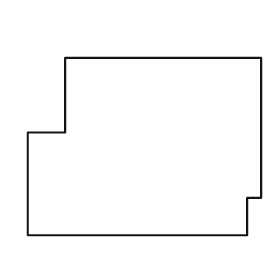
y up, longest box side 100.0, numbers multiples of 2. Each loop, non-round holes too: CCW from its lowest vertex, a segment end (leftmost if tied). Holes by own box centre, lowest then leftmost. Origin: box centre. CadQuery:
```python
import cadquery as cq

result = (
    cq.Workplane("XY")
    .moveTo(-50.0, -38.0)
    .lineTo(44.0, -38.0)
    .lineTo(44.0, -22.0)
    .lineTo(50.0, -22.0)
    .lineTo(50.0, 38.0)
    .lineTo(-34.0, 38.0)
    .lineTo(-34.0, 6.0)
    .lineTo(-50.0, 6.0)
    .close()
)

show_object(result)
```